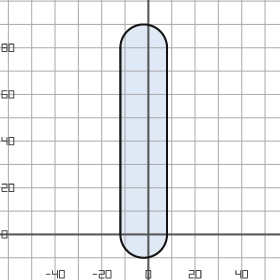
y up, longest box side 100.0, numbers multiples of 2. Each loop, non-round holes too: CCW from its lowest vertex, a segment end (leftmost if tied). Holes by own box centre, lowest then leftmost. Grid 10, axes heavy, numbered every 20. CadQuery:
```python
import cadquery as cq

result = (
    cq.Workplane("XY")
    .moveTo(-12.0, 0.0)
    .threePointArc((-2.0, -10.0), (8.0, 0.0))
    .lineTo(8.0, 80.0)
    .threePointArc((-2.0, 90.0), (-12.0, 80.0))
    .close()
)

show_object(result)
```